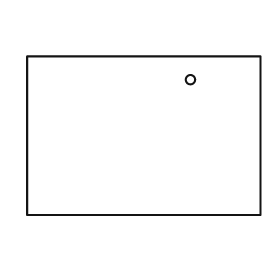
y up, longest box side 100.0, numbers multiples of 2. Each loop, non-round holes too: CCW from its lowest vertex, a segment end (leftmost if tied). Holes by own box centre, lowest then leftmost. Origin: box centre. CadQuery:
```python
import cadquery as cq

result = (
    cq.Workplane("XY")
    .moveTo(-50.0, -34.0)
    .lineTo(50.0, -34.0)
    .lineTo(50.0, 34.0)
    .lineTo(-50.0, 34.0)
    .close()
    .moveTo(20.0, 24.0)
    .circle(2.0)
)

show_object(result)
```